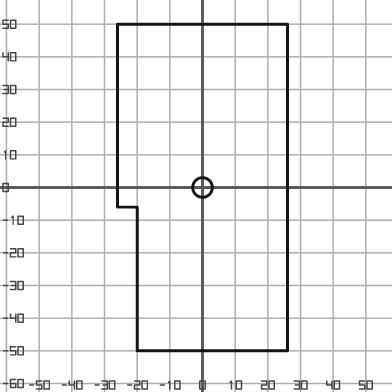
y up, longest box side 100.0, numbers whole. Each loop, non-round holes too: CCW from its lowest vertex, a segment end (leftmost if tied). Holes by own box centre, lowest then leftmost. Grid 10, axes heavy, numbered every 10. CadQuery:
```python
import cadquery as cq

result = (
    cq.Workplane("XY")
    .moveTo(-20.0, -50.0)
    .lineTo(26.0, -50.0)
    .lineTo(26.0, 50.0)
    .lineTo(-26.0, 50.0)
    .lineTo(-26.0, -6.0)
    .lineTo(-20.0, -6.0)
    .close()
    .moveTo(0.0, 0.0)
    .circle(3.0)
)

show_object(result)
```